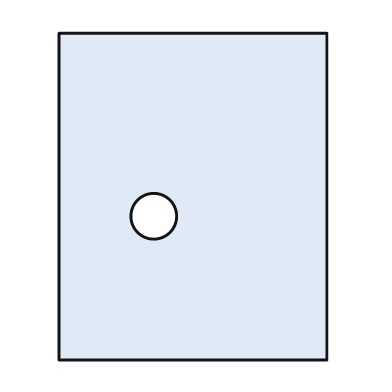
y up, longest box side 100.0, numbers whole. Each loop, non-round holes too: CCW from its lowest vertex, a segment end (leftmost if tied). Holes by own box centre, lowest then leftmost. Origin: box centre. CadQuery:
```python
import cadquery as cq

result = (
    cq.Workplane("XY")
    .moveTo(-41.0, -50.0)
    .lineTo(41.0, -50.0)
    .lineTo(41.0, 50.0)
    .lineTo(-41.0, 50.0)
    .close()
    .moveTo(-12.0, -6.0)
    .circle(7.0)
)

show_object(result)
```